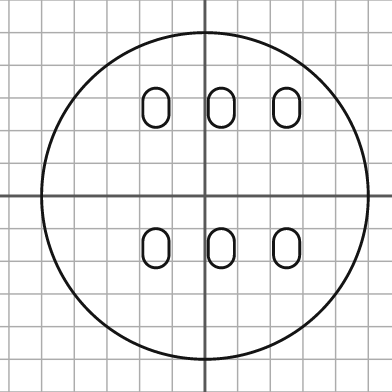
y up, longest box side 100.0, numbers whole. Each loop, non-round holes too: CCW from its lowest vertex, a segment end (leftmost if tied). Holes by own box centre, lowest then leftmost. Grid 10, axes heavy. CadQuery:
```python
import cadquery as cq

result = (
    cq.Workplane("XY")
    .moveTo(0.0, 0.0)
    .circle(50.0)
    .moveTo(-19.0, -18.0)
    .threePointArc((-15.0, -22.0), (-11.0, -18.0))
    .lineTo(-11.0, -14.0)
    .threePointArc((-15.0, -10.0), (-19.0, -14.0))
    .close()
    .moveTo(1.0, -18.0)
    .threePointArc((5.0, -22.0), (9.0, -18.0))
    .lineTo(9.0, -14.0)
    .threePointArc((5.0, -10.0), (1.0, -14.0))
    .close()
    .moveTo(21.0, -18.0)
    .threePointArc((25.0, -22.0), (29.0, -18.0))
    .lineTo(29.0, -14.0)
    .threePointArc((25.0, -10.0), (21.0, -14.0))
    .close()
    .moveTo(-19.0, 25.0)
    .threePointArc((-15.0, 21.0), (-11.0, 25.0))
    .lineTo(-11.0, 29.0)
    .threePointArc((-15.0, 33.0), (-19.0, 29.0))
    .close()
    .moveTo(1.0, 25.0)
    .threePointArc((5.0, 21.0), (9.0, 25.0))
    .lineTo(9.0, 29.0)
    .threePointArc((5.0, 33.0), (1.0, 29.0))
    .close()
    .moveTo(21.0, 25.0)
    .threePointArc((25.0, 21.0), (29.0, 25.0))
    .lineTo(29.0, 29.0)
    .threePointArc((25.0, 33.0), (21.0, 29.0))
    .close()
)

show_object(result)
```